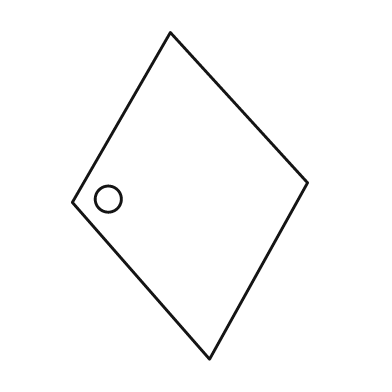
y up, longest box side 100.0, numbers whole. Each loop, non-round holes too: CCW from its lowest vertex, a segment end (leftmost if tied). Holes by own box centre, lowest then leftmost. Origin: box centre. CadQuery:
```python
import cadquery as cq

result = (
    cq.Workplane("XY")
    .moveTo(6.0, -50.0)
    .lineTo(36.0, 4.0)
    .lineTo(-6.0, 50.0)
    .lineTo(-36.0, -2.0)
    .close()
    .moveTo(-25.0, -1.0)
    .circle(4.0)
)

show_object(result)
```